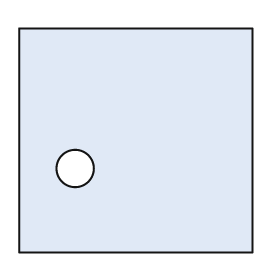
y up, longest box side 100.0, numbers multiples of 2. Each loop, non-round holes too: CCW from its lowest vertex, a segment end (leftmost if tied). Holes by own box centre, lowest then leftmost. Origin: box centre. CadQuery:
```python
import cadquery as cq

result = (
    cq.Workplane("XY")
    .moveTo(-50.0, -48.0)
    .lineTo(50.0, -48.0)
    .lineTo(50.0, 48.0)
    .lineTo(-50.0, 48.0)
    .close()
    .moveTo(-26.0, -12.0)
    .circle(8.0)
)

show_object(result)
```